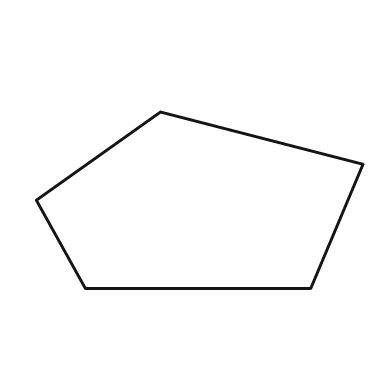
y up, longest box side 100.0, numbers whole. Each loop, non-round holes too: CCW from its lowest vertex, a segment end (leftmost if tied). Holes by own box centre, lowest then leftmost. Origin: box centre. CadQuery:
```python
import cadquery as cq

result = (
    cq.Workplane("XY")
    .moveTo(-35.0, -27.0)
    .lineTo(34.0, -27.0)
    .lineTo(50.0, 11.0)
    .lineTo(-12.0, 27.0)
    .lineTo(-50.0, 0.0)
    .close()
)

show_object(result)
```